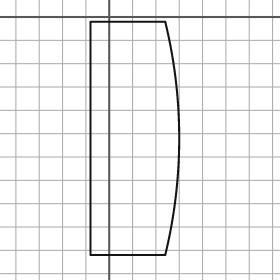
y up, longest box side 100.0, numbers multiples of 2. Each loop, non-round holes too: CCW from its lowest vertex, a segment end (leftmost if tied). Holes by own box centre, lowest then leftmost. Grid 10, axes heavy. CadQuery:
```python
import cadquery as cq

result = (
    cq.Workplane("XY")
    .moveTo(-8.0, -102.0)
    .lineTo(24.0, -102.0)
    .threePointArc((30.0, -52.0), (24.0, -2.0))
    .lineTo(-8.0, -2.0)
    .close()
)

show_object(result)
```